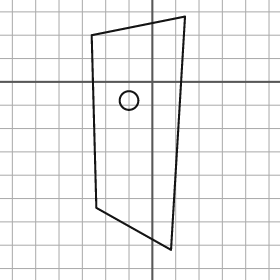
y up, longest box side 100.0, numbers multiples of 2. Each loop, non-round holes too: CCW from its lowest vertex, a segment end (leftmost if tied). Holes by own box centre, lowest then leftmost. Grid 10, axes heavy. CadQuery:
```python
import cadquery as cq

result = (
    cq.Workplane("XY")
    .moveTo(8.0, -72.0)
    .lineTo(14.0, 28.0)
    .lineTo(-26.0, 20.0)
    .lineTo(-24.0, -54.0)
    .close()
    .moveTo(-10.0, -8.0)
    .circle(4.0)
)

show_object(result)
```